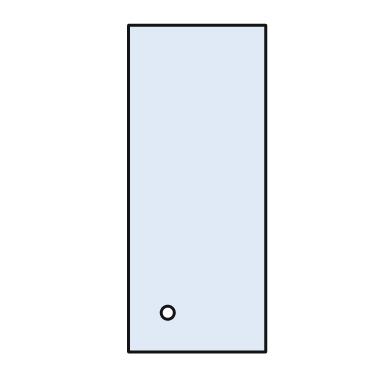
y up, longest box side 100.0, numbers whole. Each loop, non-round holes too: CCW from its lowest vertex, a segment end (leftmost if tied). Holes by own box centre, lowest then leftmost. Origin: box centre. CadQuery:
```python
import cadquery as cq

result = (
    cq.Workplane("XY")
    .moveTo(-21.0, -50.0)
    .lineTo(21.0, -50.0)
    .lineTo(21.0, 50.0)
    .lineTo(-21.0, 50.0)
    .close()
    .moveTo(-9.0, -38.0)
    .circle(2.0)
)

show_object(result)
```